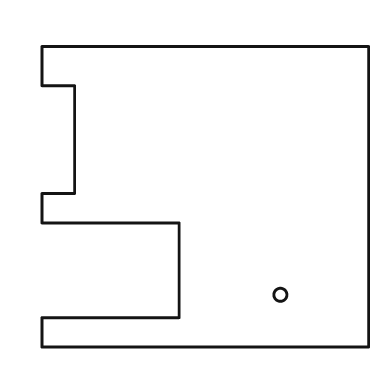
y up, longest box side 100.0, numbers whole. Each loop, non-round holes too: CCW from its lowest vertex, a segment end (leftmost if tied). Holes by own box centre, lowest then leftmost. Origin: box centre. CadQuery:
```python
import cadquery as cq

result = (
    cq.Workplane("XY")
    .moveTo(-50.0, -46.0)
    .lineTo(50.0, -46.0)
    .lineTo(50.0, 46.0)
    .lineTo(-50.0, 46.0)
    .lineTo(-50.0, 34.0)
    .lineTo(-40.0, 34.0)
    .lineTo(-40.0, 1.0)
    .lineTo(-50.0, 1.0)
    .lineTo(-50.0, -8.0)
    .lineTo(-8.0, -8.0)
    .lineTo(-8.0, -37.0)
    .lineTo(-50.0, -37.0)
    .close()
    .moveTo(23.0, -30.0)
    .circle(2.0)
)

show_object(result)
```